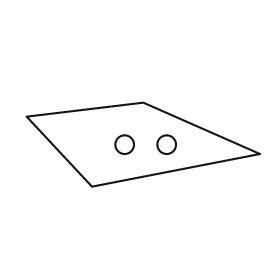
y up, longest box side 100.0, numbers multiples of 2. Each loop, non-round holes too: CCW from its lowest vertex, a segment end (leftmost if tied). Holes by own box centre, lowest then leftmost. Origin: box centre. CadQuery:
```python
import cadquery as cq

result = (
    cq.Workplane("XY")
    .moveTo(-22.0, -18.0)
    .lineTo(50.0, -4.0)
    .lineTo(0.0, 18.0)
    .lineTo(-50.0, 12.0)
    .close()
    .moveTo(-8.0, 0.0)
    .circle(4.0)
    .moveTo(10.0, 0.0)
    .circle(4.0)
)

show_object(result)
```